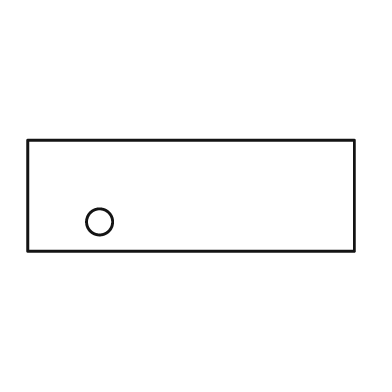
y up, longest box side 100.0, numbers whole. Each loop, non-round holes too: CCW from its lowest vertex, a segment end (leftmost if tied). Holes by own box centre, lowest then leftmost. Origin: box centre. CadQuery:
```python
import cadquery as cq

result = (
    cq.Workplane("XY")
    .moveTo(-50.0, -17.0)
    .lineTo(50.0, -17.0)
    .lineTo(50.0, 17.0)
    .lineTo(-50.0, 17.0)
    .close()
    .moveTo(-28.0, -8.0)
    .circle(4.0)
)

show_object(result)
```